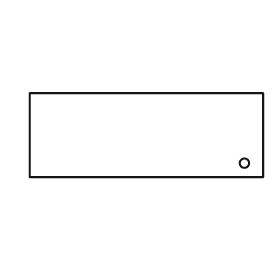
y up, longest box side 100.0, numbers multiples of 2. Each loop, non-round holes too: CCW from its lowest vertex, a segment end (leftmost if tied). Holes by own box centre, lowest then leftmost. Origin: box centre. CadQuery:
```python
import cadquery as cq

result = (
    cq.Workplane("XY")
    .moveTo(-50.0, -18.0)
    .lineTo(50.0, -18.0)
    .lineTo(50.0, 18.0)
    .lineTo(-50.0, 18.0)
    .close()
    .moveTo(42.0, -12.0)
    .circle(2.0)
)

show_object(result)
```